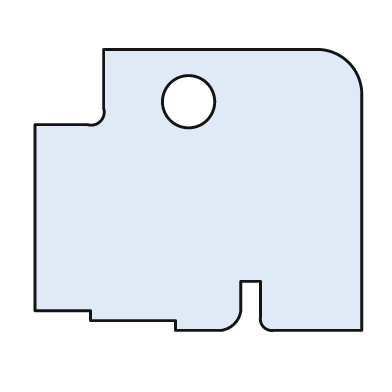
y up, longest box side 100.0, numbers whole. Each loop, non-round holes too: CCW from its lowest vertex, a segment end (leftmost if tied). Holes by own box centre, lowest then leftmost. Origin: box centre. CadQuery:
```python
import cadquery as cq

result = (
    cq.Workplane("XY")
    .moveTo(-7.0, -43.0)
    .lineTo(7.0, -43.0)
    .threePointArc((11.0, -41.0), (13.0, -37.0))
    .lineTo(13.0, -28.0)
    .lineTo(19.0, -28.0)
    .lineTo(19.0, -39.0)
    .threePointArc((20.0, -42.0), (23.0, -43.0))
    .lineTo(50.0, -43.0)
    .lineTo(50.0, 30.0)
    .threePointArc((46.0, 39.0), (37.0, 43.0))
    .lineTo(-29.0, 43.0)
    .lineTo(-29.0, 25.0)
    .threePointArc((-30.0, 21.0), (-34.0, 20.0))
    .lineTo(-50.0, 20.0)
    .lineTo(-50.0, -37.0)
    .lineTo(-33.0, -37.0)
    .lineTo(-33.0, -40.0)
    .lineTo(-7.0, -40.0)
    .close()
    .moveTo(-3.0, 27.0)
    .circle(8.0)
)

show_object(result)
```